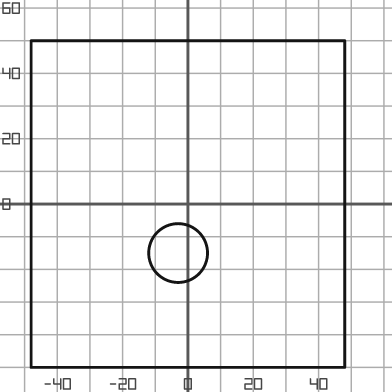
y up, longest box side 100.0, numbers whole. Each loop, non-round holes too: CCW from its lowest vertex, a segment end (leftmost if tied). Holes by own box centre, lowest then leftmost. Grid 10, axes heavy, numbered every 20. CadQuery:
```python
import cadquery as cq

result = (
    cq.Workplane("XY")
    .moveTo(-48.0, -50.0)
    .lineTo(48.0, -50.0)
    .lineTo(48.0, 50.0)
    .lineTo(-48.0, 50.0)
    .close()
    .moveTo(-3.0, -15.0)
    .circle(9.0)
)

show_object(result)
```